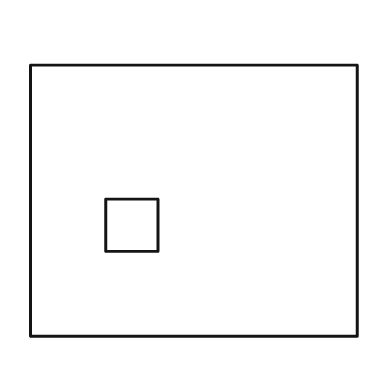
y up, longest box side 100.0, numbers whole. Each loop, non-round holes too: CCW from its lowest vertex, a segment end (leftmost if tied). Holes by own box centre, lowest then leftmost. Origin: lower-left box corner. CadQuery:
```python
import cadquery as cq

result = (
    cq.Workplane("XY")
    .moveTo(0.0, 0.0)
    .lineTo(100.0, 0.0)
    .lineTo(100.0, 83.0)
    .lineTo(0.0, 83.0)
    .close()
    .moveTo(23.0, 26.0)
    .lineTo(39.0, 26.0)
    .lineTo(39.0, 42.0)
    .lineTo(23.0, 42.0)
    .close()
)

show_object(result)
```